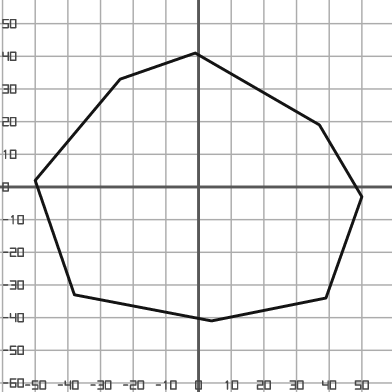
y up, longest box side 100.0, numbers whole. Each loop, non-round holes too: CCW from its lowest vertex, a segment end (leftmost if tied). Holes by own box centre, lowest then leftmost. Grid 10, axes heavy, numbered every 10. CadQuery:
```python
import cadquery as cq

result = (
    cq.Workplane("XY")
    .moveTo(4.0, -41.0)
    .lineTo(39.0, -34.0)
    .lineTo(50.0, -3.0)
    .lineTo(37.0, 19.0)
    .lineTo(-1.0, 41.0)
    .lineTo(-24.0, 33.0)
    .lineTo(-50.0, 2.0)
    .lineTo(-38.0, -33.0)
    .close()
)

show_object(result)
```